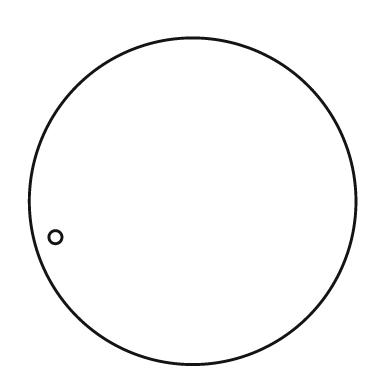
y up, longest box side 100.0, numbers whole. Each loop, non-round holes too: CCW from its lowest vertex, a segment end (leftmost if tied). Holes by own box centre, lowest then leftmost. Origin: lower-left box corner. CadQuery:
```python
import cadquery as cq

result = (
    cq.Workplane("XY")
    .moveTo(50.0, 50.0)
    .circle(50.0)
    .moveTo(8.0, 39.0)
    .circle(2.0)
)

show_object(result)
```